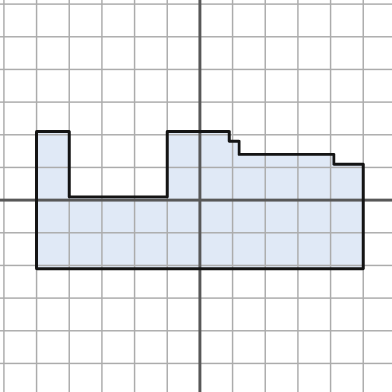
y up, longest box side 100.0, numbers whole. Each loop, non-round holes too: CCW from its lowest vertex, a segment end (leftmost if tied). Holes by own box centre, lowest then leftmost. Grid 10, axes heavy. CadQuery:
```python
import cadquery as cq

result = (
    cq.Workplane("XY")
    .moveTo(-50.0, -21.0)
    .lineTo(50.0, -21.0)
    .lineTo(50.0, 11.0)
    .lineTo(41.0, 11.0)
    .lineTo(41.0, 14.0)
    .lineTo(12.0, 14.0)
    .lineTo(12.0, 18.0)
    .lineTo(9.0, 18.0)
    .lineTo(9.0, 21.0)
    .lineTo(-10.0, 21.0)
    .lineTo(-10.0, 1.0)
    .lineTo(-40.0, 1.0)
    .lineTo(-40.0, 21.0)
    .lineTo(-50.0, 21.0)
    .close()
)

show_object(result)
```